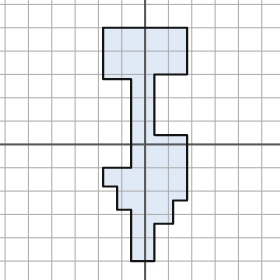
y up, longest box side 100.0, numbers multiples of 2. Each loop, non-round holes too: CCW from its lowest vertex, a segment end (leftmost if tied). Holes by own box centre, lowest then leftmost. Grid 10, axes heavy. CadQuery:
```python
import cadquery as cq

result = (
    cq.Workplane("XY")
    .moveTo(-6.0, -50.0)
    .lineTo(4.0, -50.0)
    .lineTo(4.0, -34.0)
    .lineTo(12.0, -34.0)
    .lineTo(12.0, -24.0)
    .lineTo(18.0, -24.0)
    .lineTo(18.0, 4.0)
    .lineTo(4.0, 4.0)
    .lineTo(4.0, 30.0)
    .lineTo(18.0, 30.0)
    .lineTo(18.0, 50.0)
    .lineTo(-18.0, 50.0)
    .lineTo(-18.0, 28.0)
    .lineTo(-6.0, 28.0)
    .lineTo(-6.0, -10.0)
    .lineTo(-18.0, -10.0)
    .lineTo(-18.0, -18.0)
    .lineTo(-12.0, -18.0)
    .lineTo(-12.0, -28.0)
    .lineTo(-6.0, -28.0)
    .close()
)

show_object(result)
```